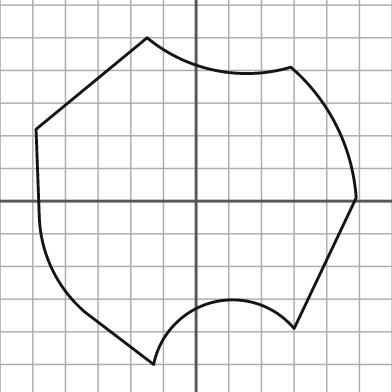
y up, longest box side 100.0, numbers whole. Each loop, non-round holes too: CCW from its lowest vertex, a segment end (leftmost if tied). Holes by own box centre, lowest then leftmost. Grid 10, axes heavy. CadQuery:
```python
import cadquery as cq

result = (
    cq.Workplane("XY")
    .moveTo(-13.0, -50.0)
    .threePointArc((5.0, -31.0), (30.0, -39.0))
    .lineTo(49.0, 1.0)
    .threePointArc((43.0, 23.0), (29.0, 41.0))
    .threePointArc((6.0, 40.0), (-15.0, 50.0))
    .lineTo(-49.0, 22.0)
    .lineTo(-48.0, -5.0)
    .threePointArc((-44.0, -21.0), (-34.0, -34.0))
    .close()
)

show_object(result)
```